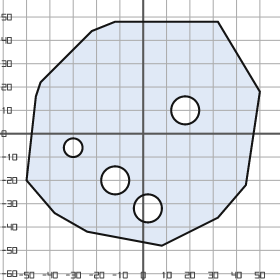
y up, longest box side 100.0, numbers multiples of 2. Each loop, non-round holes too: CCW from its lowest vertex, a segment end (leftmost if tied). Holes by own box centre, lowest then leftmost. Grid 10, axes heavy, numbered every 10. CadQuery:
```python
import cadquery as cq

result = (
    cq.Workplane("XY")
    .moveTo(8.0, -48.0)
    .lineTo(32.0, -36.0)
    .lineTo(44.0, -22.0)
    .lineTo(50.0, 18.0)
    .lineTo(32.0, 48.0)
    .lineTo(-12.0, 48.0)
    .lineTo(-22.0, 44.0)
    .lineTo(-44.0, 22.0)
    .lineTo(-46.0, 16.0)
    .lineTo(-50.0, -20.0)
    .lineTo(-38.0, -34.0)
    .lineTo(-24.0, -42.0)
    .close()
    .moveTo(2.0, -32.0)
    .circle(6.0)
    .moveTo(-12.0, -20.0)
    .circle(6.0)
    .moveTo(-30.0, -6.0)
    .circle(4.0)
    .moveTo(18.0, 10.0)
    .circle(6.0)
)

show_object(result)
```